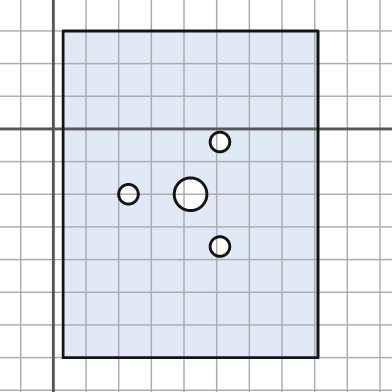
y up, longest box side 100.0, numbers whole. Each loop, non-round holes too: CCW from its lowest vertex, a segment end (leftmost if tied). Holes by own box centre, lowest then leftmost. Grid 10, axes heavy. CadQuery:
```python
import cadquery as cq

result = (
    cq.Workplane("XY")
    .moveTo(3.0, -70.0)
    .lineTo(81.0, -70.0)
    .lineTo(81.0, 30.0)
    .lineTo(3.0, 30.0)
    .close()
    .moveTo(51.0, -36.0)
    .circle(3.0)
    .moveTo(23.0, -20.0)
    .circle(3.0)
    .moveTo(42.0, -20.0)
    .circle(5.0)
    .moveTo(51.0, -4.0)
    .circle(3.0)
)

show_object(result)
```